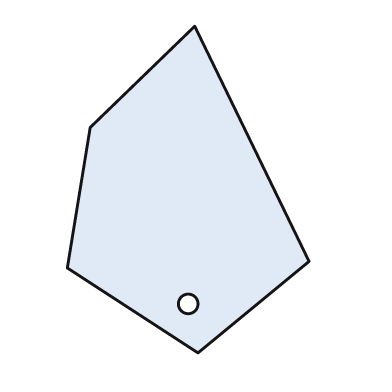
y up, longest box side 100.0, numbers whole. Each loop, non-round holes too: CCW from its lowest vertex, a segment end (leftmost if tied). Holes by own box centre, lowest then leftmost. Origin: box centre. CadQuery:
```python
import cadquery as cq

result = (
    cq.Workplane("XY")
    .moveTo(3.0, -50.0)
    .lineTo(37.0, -22.0)
    .lineTo(2.0, 50.0)
    .lineTo(-30.0, 19.0)
    .lineTo(-37.0, -24.0)
    .close()
    .moveTo(0.0, -35.0)
    .circle(3.0)
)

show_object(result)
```